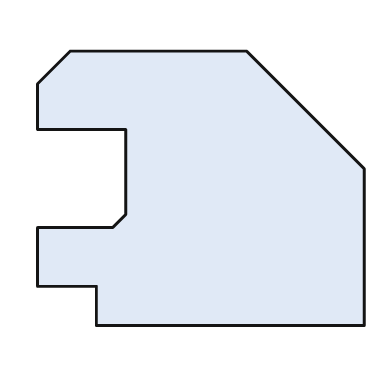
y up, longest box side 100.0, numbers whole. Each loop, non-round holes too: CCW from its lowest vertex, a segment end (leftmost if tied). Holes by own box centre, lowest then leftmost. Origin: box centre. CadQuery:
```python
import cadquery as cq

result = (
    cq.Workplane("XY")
    .moveTo(-32.0, -42.0)
    .lineTo(50.0, -42.0)
    .lineTo(50.0, 6.0)
    .lineTo(14.0, 42.0)
    .lineTo(-40.0, 42.0)
    .lineTo(-50.0, 32.0)
    .lineTo(-50.0, 18.0)
    .lineTo(-23.0, 18.0)
    .lineTo(-23.0, -8.0)
    .lineTo(-27.0, -12.0)
    .lineTo(-50.0, -12.0)
    .lineTo(-50.0, -30.0)
    .lineTo(-32.0, -30.0)
    .close()
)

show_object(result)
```